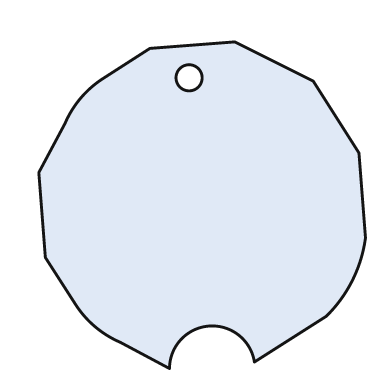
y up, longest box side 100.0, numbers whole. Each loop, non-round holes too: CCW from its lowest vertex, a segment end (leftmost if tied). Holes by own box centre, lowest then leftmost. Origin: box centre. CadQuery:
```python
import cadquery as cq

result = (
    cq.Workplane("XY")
    .moveTo(-10.0, -50.0)
    .threePointArc((2.0, -37.0), (16.0, -48.0))
    .lineTo(38.0, -34.0)
    .threePointArc((46.0, -23.0), (50.0, -10.0))
    .lineTo(48.0, 16.0)
    .lineTo(34.0, 38.0)
    .lineTo(10.0, 50.0)
    .lineTo(-16.0, 48.0)
    .lineTo(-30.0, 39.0)
    .threePointArc((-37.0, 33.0), (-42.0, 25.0))
    .lineTo(-50.0, 10.0)
    .lineTo(-48.0, -16.0)
    .lineTo(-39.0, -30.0)
    .threePointArc((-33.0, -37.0), (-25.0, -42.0))
    .close()
    .moveTo(-4.0, 39.0)
    .circle(4.0)
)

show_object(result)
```